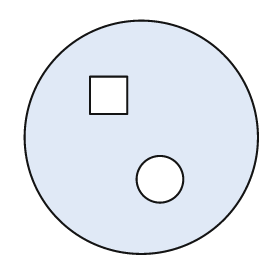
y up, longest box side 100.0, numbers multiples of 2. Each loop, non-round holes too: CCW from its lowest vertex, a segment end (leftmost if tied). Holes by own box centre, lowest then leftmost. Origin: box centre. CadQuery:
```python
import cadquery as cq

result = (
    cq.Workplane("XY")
    .moveTo(0.0, 0.0)
    .circle(50.0)
    .moveTo(8.0, -18.0)
    .circle(10.0)
    .moveTo(-22.0, 10.0)
    .lineTo(-6.0, 10.0)
    .lineTo(-6.0, 26.0)
    .lineTo(-22.0, 26.0)
    .close()
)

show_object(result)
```